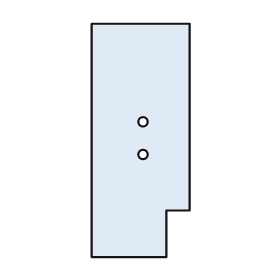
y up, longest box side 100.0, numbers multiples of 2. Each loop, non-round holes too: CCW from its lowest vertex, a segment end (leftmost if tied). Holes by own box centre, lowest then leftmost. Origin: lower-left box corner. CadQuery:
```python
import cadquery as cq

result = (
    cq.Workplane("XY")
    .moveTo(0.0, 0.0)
    .lineTo(32.0, 0.0)
    .lineTo(32.0, 20.0)
    .lineTo(42.0, 20.0)
    .lineTo(42.0, 100.0)
    .lineTo(0.0, 100.0)
    .close()
    .moveTo(22.0, 44.0)
    .circle(2.0)
    .moveTo(22.0, 58.0)
    .circle(2.0)
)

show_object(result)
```